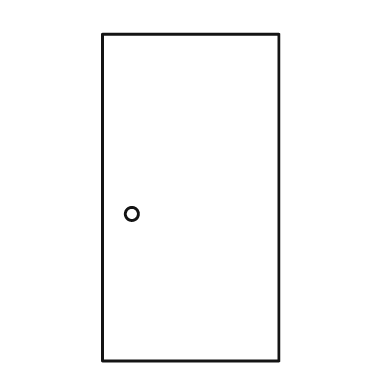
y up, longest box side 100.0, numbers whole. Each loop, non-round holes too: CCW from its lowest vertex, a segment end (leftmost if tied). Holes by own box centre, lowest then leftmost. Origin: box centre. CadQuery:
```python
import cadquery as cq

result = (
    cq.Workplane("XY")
    .moveTo(-27.0, -50.0)
    .lineTo(27.0, -50.0)
    .lineTo(27.0, 50.0)
    .lineTo(-27.0, 50.0)
    .close()
    .moveTo(-18.0, -5.0)
    .circle(2.0)
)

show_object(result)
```